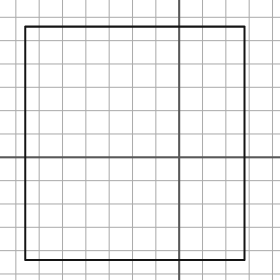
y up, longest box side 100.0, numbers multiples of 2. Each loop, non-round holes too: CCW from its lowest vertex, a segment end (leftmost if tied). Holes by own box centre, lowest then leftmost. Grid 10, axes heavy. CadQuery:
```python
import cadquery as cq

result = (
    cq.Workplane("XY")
    .moveTo(-66.0, -44.0)
    .lineTo(28.0, -44.0)
    .lineTo(28.0, 56.0)
    .lineTo(-66.0, 56.0)
    .close()
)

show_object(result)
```